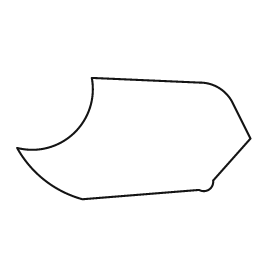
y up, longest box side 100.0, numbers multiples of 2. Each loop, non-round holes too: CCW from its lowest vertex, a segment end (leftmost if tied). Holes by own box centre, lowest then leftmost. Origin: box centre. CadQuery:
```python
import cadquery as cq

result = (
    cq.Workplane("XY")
    .moveTo(-22.0, -26.0)
    .lineTo(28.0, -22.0)
    .threePointArc((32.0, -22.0), (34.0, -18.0))
    .lineTo(50.0, 0.0)
    .lineTo(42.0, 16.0)
    .threePointArc((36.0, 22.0), (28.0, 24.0))
    .lineTo(-18.0, 26.0)
    .threePointArc((-26.0, 2.0), (-50.0, -4.0))
    .threePointArc((-38.0, -18.0), (-22.0, -26.0))
    .close()
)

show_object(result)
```